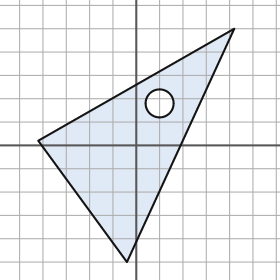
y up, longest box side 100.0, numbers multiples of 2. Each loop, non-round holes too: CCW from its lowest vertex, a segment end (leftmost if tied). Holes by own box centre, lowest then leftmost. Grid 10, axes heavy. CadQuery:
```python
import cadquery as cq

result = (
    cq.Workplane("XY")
    .moveTo(-4.0, -50.0)
    .lineTo(42.0, 50.0)
    .lineTo(-42.0, 2.0)
    .close()
    .moveTo(10.0, 18.0)
    .circle(6.0)
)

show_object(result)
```